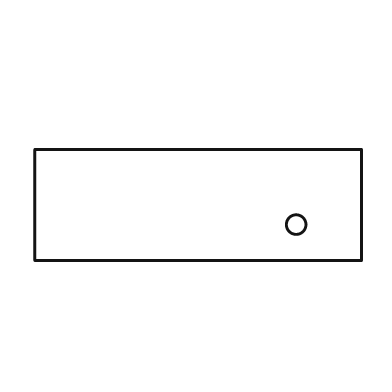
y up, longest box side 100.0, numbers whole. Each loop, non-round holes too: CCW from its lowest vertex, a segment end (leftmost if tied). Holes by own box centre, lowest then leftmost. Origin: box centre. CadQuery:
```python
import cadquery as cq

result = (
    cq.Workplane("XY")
    .moveTo(-50.0, -17.0)
    .lineTo(50.0, -17.0)
    .lineTo(50.0, 17.0)
    .lineTo(-50.0, 17.0)
    .close()
    .moveTo(30.0, -6.0)
    .circle(3.0)
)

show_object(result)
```